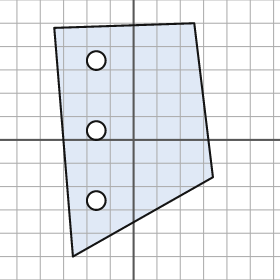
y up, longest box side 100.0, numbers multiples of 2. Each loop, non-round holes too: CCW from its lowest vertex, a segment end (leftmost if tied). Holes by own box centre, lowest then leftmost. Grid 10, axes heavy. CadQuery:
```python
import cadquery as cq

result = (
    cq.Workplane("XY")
    .moveTo(-26.0, -50.0)
    .lineTo(34.0, -16.0)
    .lineTo(26.0, 50.0)
    .lineTo(-34.0, 48.0)
    .close()
    .moveTo(-16.0, -26.0)
    .circle(4.0)
    .moveTo(-16.0, 4.0)
    .circle(4.0)
    .moveTo(-16.0, 34.0)
    .circle(4.0)
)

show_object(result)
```